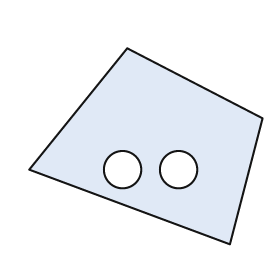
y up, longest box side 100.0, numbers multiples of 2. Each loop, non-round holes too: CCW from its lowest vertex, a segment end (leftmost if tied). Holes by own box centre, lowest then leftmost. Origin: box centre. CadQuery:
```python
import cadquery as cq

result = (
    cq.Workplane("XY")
    .moveTo(36.0, -42.0)
    .lineTo(50.0, 12.0)
    .lineTo(-8.0, 42.0)
    .lineTo(-50.0, -10.0)
    .close()
    .moveTo(-10.0, -10.0)
    .circle(8.0)
    .moveTo(14.0, -10.0)
    .circle(8.0)
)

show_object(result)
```